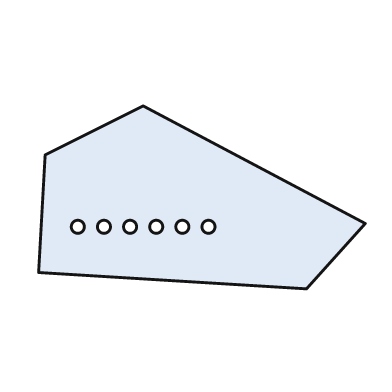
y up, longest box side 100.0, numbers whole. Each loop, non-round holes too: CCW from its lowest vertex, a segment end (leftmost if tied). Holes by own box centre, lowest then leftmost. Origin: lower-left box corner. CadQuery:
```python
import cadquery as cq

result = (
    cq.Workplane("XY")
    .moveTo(82.0, 0.0)
    .lineTo(100.0, 20.0)
    .lineTo(32.0, 56.0)
    .lineTo(2.0, 41.0)
    .lineTo(0.0, 5.0)
    .close()
    .moveTo(12.0, 19.0)
    .circle(2.0)
    .moveTo(20.0, 19.0)
    .circle(2.0)
    .moveTo(28.0, 19.0)
    .circle(2.0)
    .moveTo(36.0, 19.0)
    .circle(2.0)
    .moveTo(44.0, 19.0)
    .circle(2.0)
    .moveTo(52.0, 19.0)
    .circle(2.0)
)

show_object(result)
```